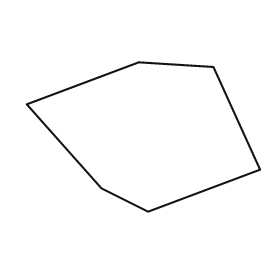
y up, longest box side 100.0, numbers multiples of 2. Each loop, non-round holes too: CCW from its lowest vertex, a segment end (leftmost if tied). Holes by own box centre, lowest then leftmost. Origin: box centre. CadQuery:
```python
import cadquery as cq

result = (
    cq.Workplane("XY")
    .moveTo(2.0, -32.0)
    .lineTo(50.0, -14.0)
    .lineTo(30.0, 30.0)
    .lineTo(-2.0, 32.0)
    .lineTo(-50.0, 14.0)
    .lineTo(-18.0, -22.0)
    .close()
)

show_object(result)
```